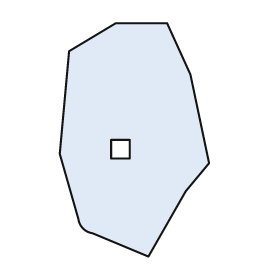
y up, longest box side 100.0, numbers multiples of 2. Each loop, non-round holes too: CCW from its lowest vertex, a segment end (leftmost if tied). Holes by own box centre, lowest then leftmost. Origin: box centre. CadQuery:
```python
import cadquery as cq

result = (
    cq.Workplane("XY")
    .moveTo(6.0, -50.0)
    .lineTo(22.0, -22.0)
    .lineTo(32.0, -10.0)
    .lineTo(24.0, 28.0)
    .lineTo(14.0, 50.0)
    .lineTo(-8.0, 50.0)
    .lineTo(-28.0, 38.0)
    .lineTo(-32.0, -6.0)
    .lineTo(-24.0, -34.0)
    .threePointArc((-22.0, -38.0), (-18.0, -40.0))
    .close()
    .moveTo(-10.0, -8.0)
    .lineTo(-2.0, -8.0)
    .lineTo(-2.0, 0.0)
    .lineTo(-10.0, 0.0)
    .close()
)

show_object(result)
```